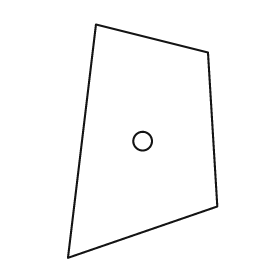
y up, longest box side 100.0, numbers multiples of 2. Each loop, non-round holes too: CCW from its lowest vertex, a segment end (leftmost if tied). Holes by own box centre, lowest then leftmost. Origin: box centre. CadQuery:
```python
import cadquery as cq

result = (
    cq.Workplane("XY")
    .moveTo(-32.0, -50.0)
    .lineTo(32.0, -28.0)
    .lineTo(28.0, 38.0)
    .lineTo(-20.0, 50.0)
    .close()
    .moveTo(0.0, 0.0)
    .circle(4.0)
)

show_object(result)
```